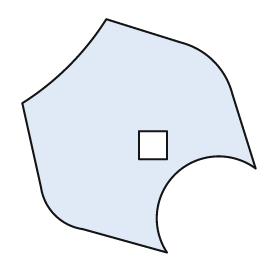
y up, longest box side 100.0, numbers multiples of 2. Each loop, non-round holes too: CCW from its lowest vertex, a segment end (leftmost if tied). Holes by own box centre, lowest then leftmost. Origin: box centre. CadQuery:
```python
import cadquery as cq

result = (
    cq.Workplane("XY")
    .moveTo(12.0, -50.0)
    .threePointArc((16.0, -16.0), (50.0, -14.0))
    .lineTo(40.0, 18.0)
    .threePointArc((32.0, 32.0), (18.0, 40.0))
    .lineTo(-14.0, 50.0)
    .threePointArc((-30.0, 30.0), (-50.0, 14.0))
    .lineTo(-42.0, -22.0)
    .threePointArc((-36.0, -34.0), (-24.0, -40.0))
    .close()
    .moveTo(0.0, -10.0)
    .lineTo(12.0, -10.0)
    .lineTo(12.0, 2.0)
    .lineTo(0.0, 2.0)
    .close()
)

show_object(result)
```